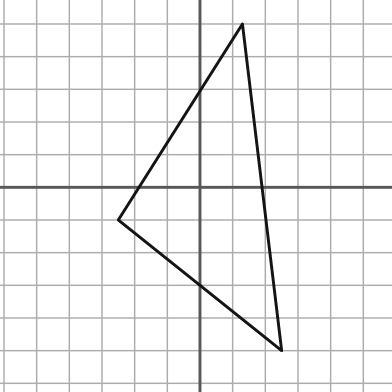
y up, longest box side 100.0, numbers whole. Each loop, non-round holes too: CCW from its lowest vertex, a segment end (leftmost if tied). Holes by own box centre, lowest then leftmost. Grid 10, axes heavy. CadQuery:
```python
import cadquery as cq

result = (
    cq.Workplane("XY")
    .moveTo(25.0, -50.0)
    .lineTo(13.0, 50.0)
    .lineTo(-25.0, -10.0)
    .close()
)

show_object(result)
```